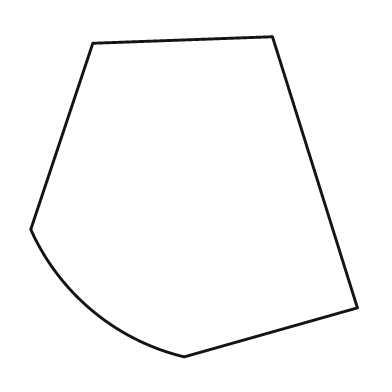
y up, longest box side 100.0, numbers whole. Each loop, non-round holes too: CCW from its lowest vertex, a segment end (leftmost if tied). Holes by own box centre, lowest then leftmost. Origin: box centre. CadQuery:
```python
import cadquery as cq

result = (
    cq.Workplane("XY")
    .moveTo(-3.0, -49.0)
    .lineTo(50.0, -34.0)
    .lineTo(24.0, 49.0)
    .lineTo(-31.0, 47.0)
    .lineTo(-50.0, -10.0)
    .threePointArc((-31.0, -35.0), (-3.0, -49.0))
    .close()
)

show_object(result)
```